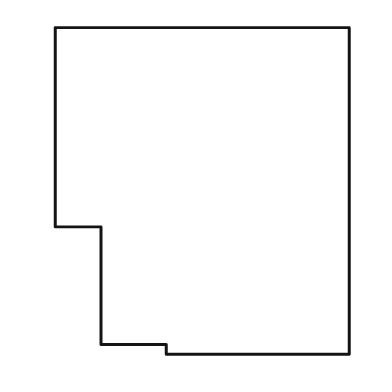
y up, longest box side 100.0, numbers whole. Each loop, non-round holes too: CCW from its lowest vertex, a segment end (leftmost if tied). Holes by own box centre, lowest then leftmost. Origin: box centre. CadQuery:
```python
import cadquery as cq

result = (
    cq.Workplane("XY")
    .moveTo(-11.0, -50.0)
    .lineTo(45.0, -50.0)
    .lineTo(45.0, 50.0)
    .lineTo(-45.0, 50.0)
    .lineTo(-45.0, -11.0)
    .lineTo(-31.0, -11.0)
    .lineTo(-31.0, -47.0)
    .lineTo(-11.0, -47.0)
    .close()
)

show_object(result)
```